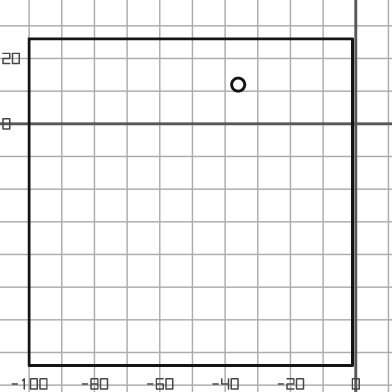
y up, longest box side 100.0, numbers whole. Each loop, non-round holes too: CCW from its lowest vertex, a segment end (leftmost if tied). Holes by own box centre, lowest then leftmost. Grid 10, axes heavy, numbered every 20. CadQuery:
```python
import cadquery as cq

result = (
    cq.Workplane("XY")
    .moveTo(-100.0, -74.0)
    .lineTo(-1.0, -74.0)
    .lineTo(-1.0, 26.0)
    .lineTo(-100.0, 26.0)
    .close()
    .moveTo(-36.0, 12.0)
    .circle(2.0)
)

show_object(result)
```